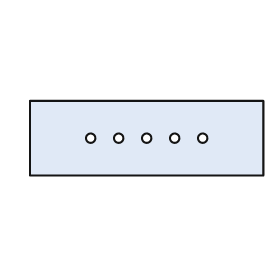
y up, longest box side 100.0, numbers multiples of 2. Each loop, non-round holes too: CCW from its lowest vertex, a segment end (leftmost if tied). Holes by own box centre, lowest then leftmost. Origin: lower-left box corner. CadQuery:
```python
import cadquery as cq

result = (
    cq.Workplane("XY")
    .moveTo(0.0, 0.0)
    .lineTo(100.0, 0.0)
    .lineTo(100.0, 32.0)
    .lineTo(0.0, 32.0)
    .close()
    .moveTo(26.0, 16.0)
    .circle(2.0)
    .moveTo(38.0, 16.0)
    .circle(2.0)
    .moveTo(50.0, 16.0)
    .circle(2.0)
    .moveTo(62.0, 16.0)
    .circle(2.0)
    .moveTo(74.0, 16.0)
    .circle(2.0)
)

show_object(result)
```